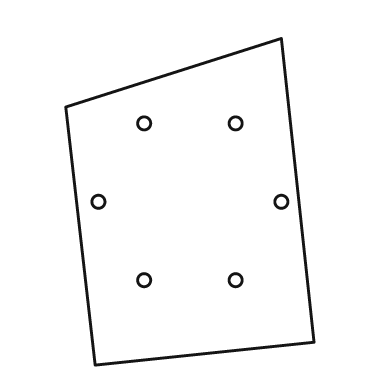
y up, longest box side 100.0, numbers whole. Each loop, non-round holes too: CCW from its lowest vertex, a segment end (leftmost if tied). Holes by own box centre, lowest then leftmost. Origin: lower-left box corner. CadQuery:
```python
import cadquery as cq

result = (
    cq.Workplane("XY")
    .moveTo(9.0, 0.0)
    .lineTo(76.0, 7.0)
    .lineTo(66.0, 100.0)
    .lineTo(0.0, 79.0)
    .close()
    .moveTo(24.0, 26.0)
    .circle(2.0)
    .moveTo(52.0, 26.0)
    .circle(2.0)
    .moveTo(10.0, 50.0)
    .circle(2.0)
    .moveTo(66.0, 50.0)
    .circle(2.0)
    .moveTo(24.0, 74.0)
    .circle(2.0)
    .moveTo(52.0, 74.0)
    .circle(2.0)
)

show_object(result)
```